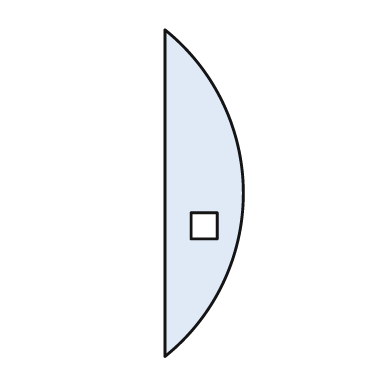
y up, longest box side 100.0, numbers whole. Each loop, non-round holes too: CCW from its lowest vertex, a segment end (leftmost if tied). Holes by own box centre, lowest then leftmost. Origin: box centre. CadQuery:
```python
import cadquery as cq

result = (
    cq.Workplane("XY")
    .moveTo(-12.0, -50.0)
    .threePointArc((12.0, 0.0), (-12.0, 50.0))
    .close()
    .moveTo(-4.0, -14.0)
    .lineTo(4.0, -14.0)
    .lineTo(4.0, -6.0)
    .lineTo(-4.0, -6.0)
    .close()
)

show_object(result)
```